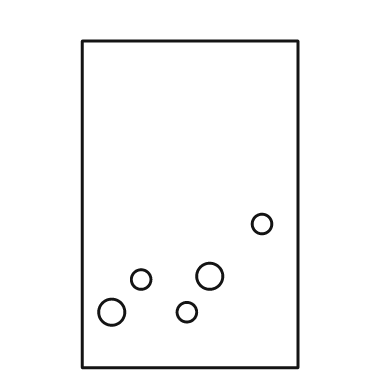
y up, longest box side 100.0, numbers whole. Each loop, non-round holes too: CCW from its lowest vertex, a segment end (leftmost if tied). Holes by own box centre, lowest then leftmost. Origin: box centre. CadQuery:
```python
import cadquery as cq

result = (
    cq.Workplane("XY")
    .moveTo(-33.0, -50.0)
    .lineTo(33.0, -50.0)
    .lineTo(33.0, 50.0)
    .lineTo(-33.0, 50.0)
    .close()
    .moveTo(-24.0, -33.0)
    .circle(4.0)
    .moveTo(-1.0, -33.0)
    .circle(3.0)
    .moveTo(-15.0, -23.0)
    .circle(3.0)
    .moveTo(6.0, -22.0)
    .circle(4.0)
    .moveTo(22.0, -6.0)
    .circle(3.0)
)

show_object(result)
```